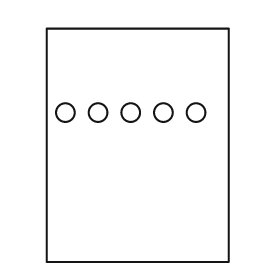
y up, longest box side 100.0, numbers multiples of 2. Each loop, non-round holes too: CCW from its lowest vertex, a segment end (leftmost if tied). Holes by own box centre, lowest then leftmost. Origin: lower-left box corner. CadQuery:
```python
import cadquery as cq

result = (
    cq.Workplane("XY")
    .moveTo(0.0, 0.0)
    .lineTo(78.0, 0.0)
    .lineTo(78.0, 100.0)
    .lineTo(0.0, 100.0)
    .close()
    .moveTo(8.0, 64.0)
    .circle(4.0)
    .moveTo(22.0, 64.0)
    .circle(4.0)
    .moveTo(36.0, 64.0)
    .circle(4.0)
    .moveTo(50.0, 64.0)
    .circle(4.0)
    .moveTo(64.0, 64.0)
    .circle(4.0)
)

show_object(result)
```